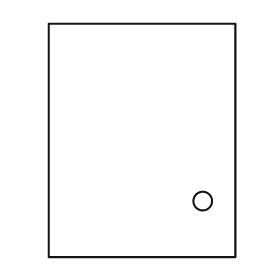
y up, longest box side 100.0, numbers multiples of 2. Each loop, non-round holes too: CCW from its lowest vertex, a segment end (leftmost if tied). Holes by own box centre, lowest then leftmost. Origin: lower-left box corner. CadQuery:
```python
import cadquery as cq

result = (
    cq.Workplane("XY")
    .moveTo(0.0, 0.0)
    .lineTo(80.0, 0.0)
    .lineTo(80.0, 100.0)
    .lineTo(0.0, 100.0)
    .close()
    .moveTo(66.0, 24.0)
    .circle(4.0)
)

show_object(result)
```